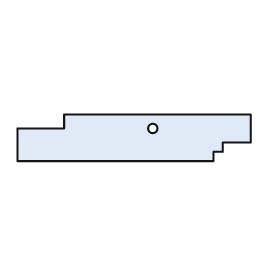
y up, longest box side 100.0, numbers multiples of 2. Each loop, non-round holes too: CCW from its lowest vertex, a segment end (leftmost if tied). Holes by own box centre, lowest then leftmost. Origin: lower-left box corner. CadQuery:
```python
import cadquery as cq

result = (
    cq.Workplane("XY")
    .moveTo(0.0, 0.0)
    .lineTo(84.0, 0.0)
    .lineTo(84.0, 4.0)
    .lineTo(88.0, 4.0)
    .lineTo(88.0, 8.0)
    .lineTo(100.0, 8.0)
    .lineTo(100.0, 20.0)
    .lineTo(20.0, 20.0)
    .lineTo(20.0, 14.0)
    .lineTo(0.0, 14.0)
    .close()
    .moveTo(58.0, 14.0)
    .circle(2.0)
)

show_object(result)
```